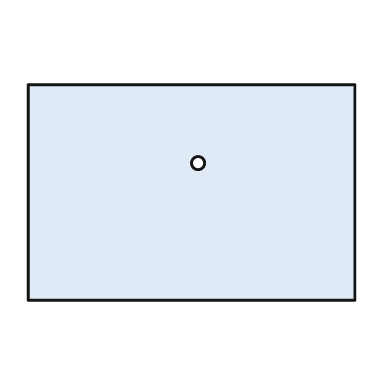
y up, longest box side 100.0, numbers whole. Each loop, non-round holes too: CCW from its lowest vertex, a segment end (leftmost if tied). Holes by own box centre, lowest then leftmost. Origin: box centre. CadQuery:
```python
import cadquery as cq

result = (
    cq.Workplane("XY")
    .moveTo(-50.0, -33.0)
    .lineTo(50.0, -33.0)
    .lineTo(50.0, 33.0)
    .lineTo(-50.0, 33.0)
    .close()
    .moveTo(2.0, 9.0)
    .circle(2.0)
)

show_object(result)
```